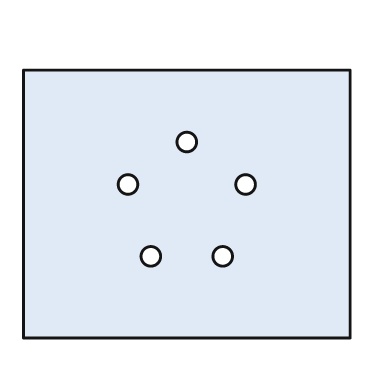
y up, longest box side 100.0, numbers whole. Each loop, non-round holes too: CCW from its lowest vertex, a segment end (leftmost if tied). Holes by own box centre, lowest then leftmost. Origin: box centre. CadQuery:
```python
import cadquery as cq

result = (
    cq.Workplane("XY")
    .moveTo(-50.0, -41.0)
    .lineTo(50.0, -41.0)
    .lineTo(50.0, 41.0)
    .lineTo(-50.0, 41.0)
    .close()
    .moveTo(-11.0, -16.0)
    .circle(3.0)
    .moveTo(11.0, -16.0)
    .circle(3.0)
    .moveTo(-18.0, 6.0)
    .circle(3.0)
    .moveTo(18.0, 6.0)
    .circle(3.0)
    .moveTo(0.0, 19.0)
    .circle(3.0)
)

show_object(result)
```